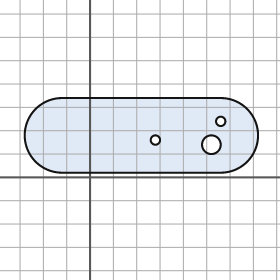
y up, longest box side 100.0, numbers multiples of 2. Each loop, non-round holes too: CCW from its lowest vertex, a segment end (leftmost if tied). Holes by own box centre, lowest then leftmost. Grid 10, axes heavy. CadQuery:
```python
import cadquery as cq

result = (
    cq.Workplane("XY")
    .moveTo(-12.0, 2.0)
    .lineTo(56.0, 2.0)
    .threePointArc((72.0, 18.0), (56.0, 34.0))
    .lineTo(-12.0, 34.0)
    .threePointArc((-28.0, 18.0), (-12.0, 2.0))
    .close()
    .moveTo(52.0, 14.0)
    .circle(4.0)
    .moveTo(28.0, 16.0)
    .circle(2.0)
    .moveTo(56.0, 24.0)
    .circle(2.0)
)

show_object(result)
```